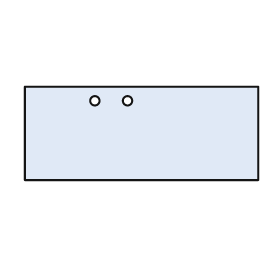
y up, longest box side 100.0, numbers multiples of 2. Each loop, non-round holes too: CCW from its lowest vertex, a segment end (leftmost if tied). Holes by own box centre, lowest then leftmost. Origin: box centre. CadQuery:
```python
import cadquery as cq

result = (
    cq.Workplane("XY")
    .moveTo(-50.0, -20.0)
    .lineTo(50.0, -20.0)
    .lineTo(50.0, 20.0)
    .lineTo(-50.0, 20.0)
    .close()
    .moveTo(-20.0, 14.0)
    .circle(2.0)
    .moveTo(-6.0, 14.0)
    .circle(2.0)
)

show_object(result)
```